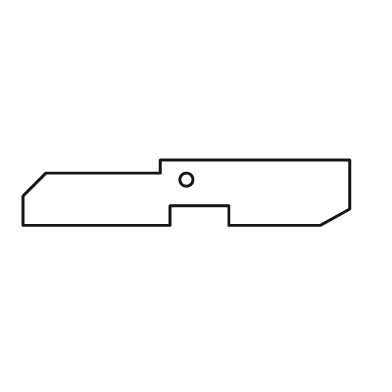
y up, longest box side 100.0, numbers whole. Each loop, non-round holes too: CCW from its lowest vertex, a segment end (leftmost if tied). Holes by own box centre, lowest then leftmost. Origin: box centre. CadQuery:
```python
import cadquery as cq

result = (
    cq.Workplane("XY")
    .moveTo(-50.0, -10.0)
    .lineTo(-5.0, -10.0)
    .lineTo(-5.0, -4.0)
    .lineTo(13.0, -4.0)
    .lineTo(13.0, -10.0)
    .lineTo(41.0, -10.0)
    .lineTo(50.0, -5.0)
    .lineTo(50.0, 10.0)
    .lineTo(-8.0, 10.0)
    .lineTo(-8.0, 6.0)
    .lineTo(-43.0, 6.0)
    .lineTo(-50.0, -1.0)
    .close()
    .moveTo(0.0, 4.0)
    .circle(2.0)
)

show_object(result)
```